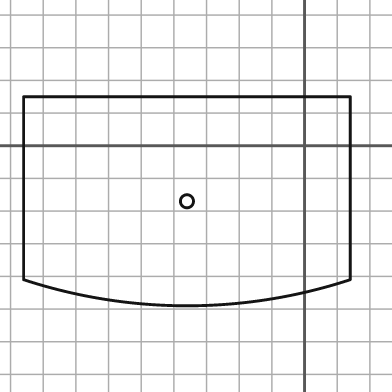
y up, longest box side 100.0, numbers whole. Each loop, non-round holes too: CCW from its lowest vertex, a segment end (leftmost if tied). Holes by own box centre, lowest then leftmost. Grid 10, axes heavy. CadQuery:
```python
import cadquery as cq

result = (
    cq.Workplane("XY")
    .moveTo(-86.0, -41.0)
    .threePointArc((-36.0, -49.0), (14.0, -41.0))
    .lineTo(14.0, 15.0)
    .lineTo(-86.0, 15.0)
    .close()
    .moveTo(-36.0, -17.0)
    .circle(2.0)
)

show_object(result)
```